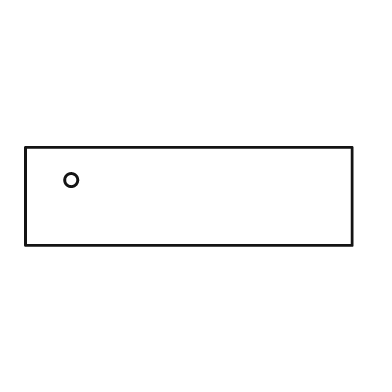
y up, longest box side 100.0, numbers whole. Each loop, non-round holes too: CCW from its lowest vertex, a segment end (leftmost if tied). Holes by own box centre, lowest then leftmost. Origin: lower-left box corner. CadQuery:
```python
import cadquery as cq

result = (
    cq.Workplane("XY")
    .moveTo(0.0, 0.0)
    .lineTo(100.0, 0.0)
    .lineTo(100.0, 30.0)
    .lineTo(0.0, 30.0)
    .close()
    .moveTo(14.0, 20.0)
    .circle(2.0)
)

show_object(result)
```